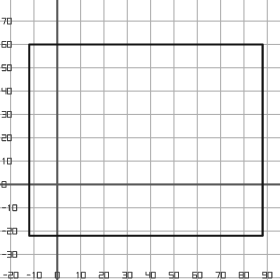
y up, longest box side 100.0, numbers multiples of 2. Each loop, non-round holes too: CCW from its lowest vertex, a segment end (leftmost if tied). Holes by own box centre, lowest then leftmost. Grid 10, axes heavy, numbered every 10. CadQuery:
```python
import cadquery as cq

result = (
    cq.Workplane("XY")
    .moveTo(-12.0, -22.0)
    .lineTo(88.0, -22.0)
    .lineTo(88.0, 60.0)
    .lineTo(-12.0, 60.0)
    .close()
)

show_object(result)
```